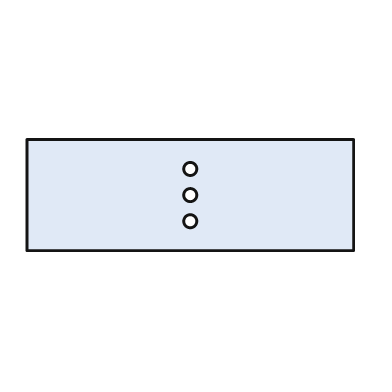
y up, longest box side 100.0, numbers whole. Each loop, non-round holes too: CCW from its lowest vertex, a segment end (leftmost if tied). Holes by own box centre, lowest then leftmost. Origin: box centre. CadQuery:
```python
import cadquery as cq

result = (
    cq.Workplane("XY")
    .moveTo(-50.0, -17.0)
    .lineTo(50.0, -17.0)
    .lineTo(50.0, 17.0)
    .lineTo(-50.0, 17.0)
    .close()
    .moveTo(0.0, -8.0)
    .circle(2.0)
    .moveTo(0.0, 0.0)
    .circle(2.0)
    .moveTo(0.0, 8.0)
    .circle(2.0)
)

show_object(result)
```